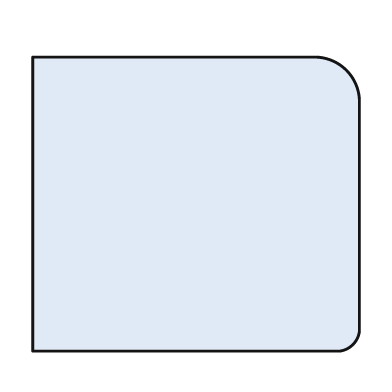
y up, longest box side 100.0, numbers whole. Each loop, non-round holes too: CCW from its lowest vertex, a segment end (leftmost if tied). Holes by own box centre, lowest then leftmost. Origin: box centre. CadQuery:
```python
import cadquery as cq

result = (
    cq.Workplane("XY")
    .moveTo(-50.0, -45.0)
    .lineTo(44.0, -45.0)
    .threePointArc((48.0, -43.0), (50.0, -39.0))
    .lineTo(50.0, 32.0)
    .threePointArc((46.0, 41.0), (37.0, 45.0))
    .lineTo(-50.0, 45.0)
    .close()
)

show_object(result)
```